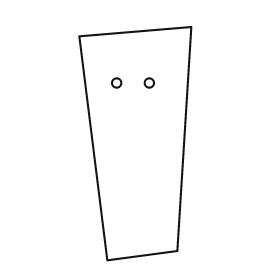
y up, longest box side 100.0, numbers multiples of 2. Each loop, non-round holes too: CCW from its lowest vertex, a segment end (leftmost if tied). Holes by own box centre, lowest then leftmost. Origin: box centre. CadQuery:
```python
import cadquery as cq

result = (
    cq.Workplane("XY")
    .moveTo(-12.0, -50.0)
    .lineTo(18.0, -46.0)
    .lineTo(24.0, 50.0)
    .lineTo(-24.0, 46.0)
    .close()
    .moveTo(-8.0, 26.0)
    .circle(2.0)
    .moveTo(6.0, 26.0)
    .circle(2.0)
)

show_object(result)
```